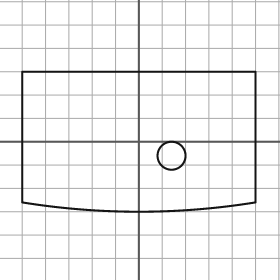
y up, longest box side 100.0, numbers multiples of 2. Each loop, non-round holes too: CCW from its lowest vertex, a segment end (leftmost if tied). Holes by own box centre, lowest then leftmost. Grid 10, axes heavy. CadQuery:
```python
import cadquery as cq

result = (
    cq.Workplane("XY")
    .moveTo(-50.0, -26.0)
    .threePointArc((0.0, -30.0), (50.0, -26.0))
    .lineTo(50.0, 30.0)
    .lineTo(-50.0, 30.0)
    .close()
    .moveTo(14.0, -6.0)
    .circle(6.0)
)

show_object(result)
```